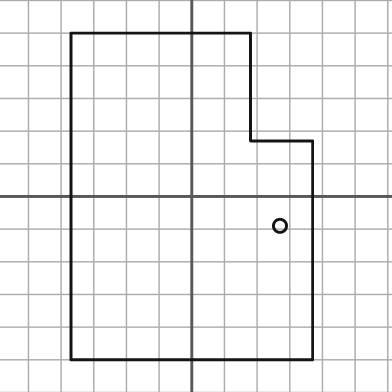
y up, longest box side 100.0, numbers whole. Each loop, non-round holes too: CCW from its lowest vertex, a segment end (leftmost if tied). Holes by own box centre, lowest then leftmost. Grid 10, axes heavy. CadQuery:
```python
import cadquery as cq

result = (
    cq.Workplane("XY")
    .moveTo(-37.0, -50.0)
    .lineTo(37.0, -50.0)
    .lineTo(37.0, 17.0)
    .lineTo(18.0, 17.0)
    .lineTo(18.0, 50.0)
    .lineTo(-37.0, 50.0)
    .close()
    .moveTo(27.0, -9.0)
    .circle(2.0)
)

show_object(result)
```